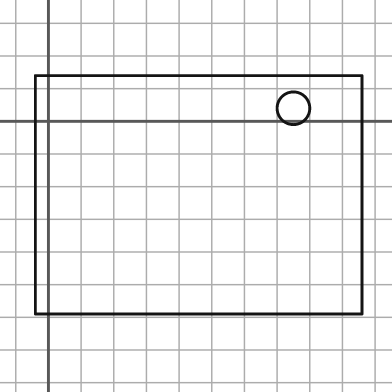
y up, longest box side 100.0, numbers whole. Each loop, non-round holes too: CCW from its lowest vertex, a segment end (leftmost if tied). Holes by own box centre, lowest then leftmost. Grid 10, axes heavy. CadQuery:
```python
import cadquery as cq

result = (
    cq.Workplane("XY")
    .moveTo(-4.0, -59.0)
    .lineTo(96.0, -59.0)
    .lineTo(96.0, 14.0)
    .lineTo(-4.0, 14.0)
    .close()
    .moveTo(75.0, 4.0)
    .circle(5.0)
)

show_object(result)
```